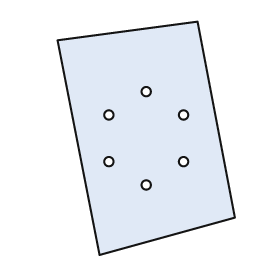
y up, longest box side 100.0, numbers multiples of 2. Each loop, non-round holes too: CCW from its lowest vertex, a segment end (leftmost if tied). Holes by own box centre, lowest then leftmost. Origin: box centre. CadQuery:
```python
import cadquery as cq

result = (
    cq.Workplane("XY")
    .moveTo(-20.0, -50.0)
    .lineTo(38.0, -34.0)
    .lineTo(22.0, 50.0)
    .lineTo(-38.0, 42.0)
    .close()
    .moveTo(0.0, -20.0)
    .circle(2.0)
    .moveTo(-16.0, -10.0)
    .circle(2.0)
    .moveTo(16.0, -10.0)
    .circle(2.0)
    .moveTo(-16.0, 10.0)
    .circle(2.0)
    .moveTo(16.0, 10.0)
    .circle(2.0)
    .moveTo(0.0, 20.0)
    .circle(2.0)
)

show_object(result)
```